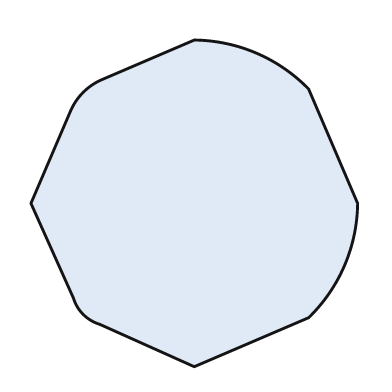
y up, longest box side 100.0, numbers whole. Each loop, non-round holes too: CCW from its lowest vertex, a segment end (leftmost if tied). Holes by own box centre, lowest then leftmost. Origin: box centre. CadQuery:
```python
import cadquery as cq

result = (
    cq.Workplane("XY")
    .moveTo(0.0, -50.0)
    .lineTo(35.0, -35.0)
    .threePointArc((46.0, -19.0), (50.0, 0.0))
    .lineTo(35.0, 35.0)
    .threePointArc((19.0, 46.0), (0.0, 50.0))
    .lineTo(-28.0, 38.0)
    .threePointArc((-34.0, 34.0), (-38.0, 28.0))
    .lineTo(-50.0, 0.0)
    .lineTo(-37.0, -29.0)
    .threePointArc((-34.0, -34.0), (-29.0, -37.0))
    .close()
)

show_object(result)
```